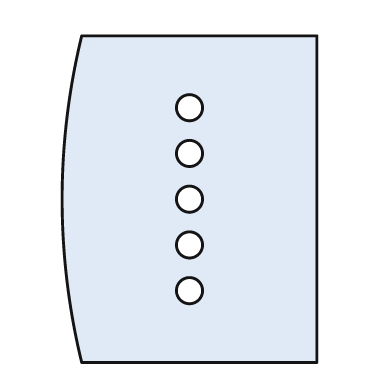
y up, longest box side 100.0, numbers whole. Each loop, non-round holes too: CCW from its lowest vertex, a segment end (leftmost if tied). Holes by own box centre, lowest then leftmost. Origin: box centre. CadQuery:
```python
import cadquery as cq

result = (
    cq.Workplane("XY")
    .moveTo(-33.0, -50.0)
    .lineTo(39.0, -50.0)
    .lineTo(39.0, 50.0)
    .lineTo(-33.0, 50.0)
    .threePointArc((-39.0, 0.0), (-33.0, -50.0))
    .close()
    .moveTo(0.0, -28.0)
    .circle(4.0)
    .moveTo(0.0, -14.0)
    .circle(4.0)
    .moveTo(0.0, 0.0)
    .circle(4.0)
    .moveTo(0.0, 14.0)
    .circle(4.0)
    .moveTo(0.0, 28.0)
    .circle(4.0)
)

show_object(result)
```